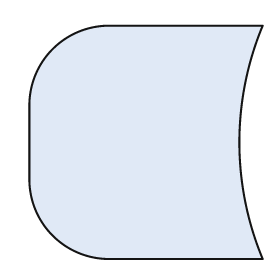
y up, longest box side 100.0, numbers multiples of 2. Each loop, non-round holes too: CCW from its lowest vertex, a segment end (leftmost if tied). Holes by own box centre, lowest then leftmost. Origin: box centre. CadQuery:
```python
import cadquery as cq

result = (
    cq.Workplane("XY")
    .moveTo(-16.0, -50.0)
    .lineTo(50.0, -50.0)
    .threePointArc((40.0, 0.0), (50.0, 50.0))
    .lineTo(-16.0, 50.0)
    .threePointArc((-40.0, 40.0), (-50.0, 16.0))
    .lineTo(-50.0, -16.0)
    .threePointArc((-40.0, -40.0), (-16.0, -50.0))
    .close()
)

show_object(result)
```